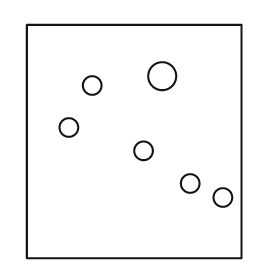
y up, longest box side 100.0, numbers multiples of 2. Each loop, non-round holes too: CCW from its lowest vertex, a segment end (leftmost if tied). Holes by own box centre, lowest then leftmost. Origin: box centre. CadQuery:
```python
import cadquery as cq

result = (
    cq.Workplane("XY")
    .moveTo(-46.0, -50.0)
    .lineTo(46.0, -50.0)
    .lineTo(46.0, 50.0)
    .lineTo(-46.0, 50.0)
    .close()
    .moveTo(38.0, -24.0)
    .circle(4.0)
    .moveTo(24.0, -18.0)
    .circle(4.0)
    .moveTo(4.0, -4.0)
    .circle(4.0)
    .moveTo(-28.0, 6.0)
    .circle(4.0)
    .moveTo(-18.0, 24.0)
    .circle(4.0)
    .moveTo(12.0, 28.0)
    .circle(6.0)
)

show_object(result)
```